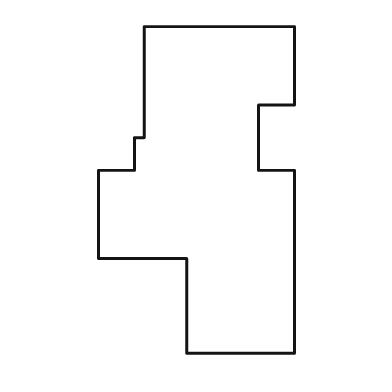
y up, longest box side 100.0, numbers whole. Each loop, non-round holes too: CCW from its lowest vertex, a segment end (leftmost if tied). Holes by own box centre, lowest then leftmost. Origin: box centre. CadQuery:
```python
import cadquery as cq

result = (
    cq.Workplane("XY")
    .moveTo(-3.0, -50.0)
    .lineTo(30.0, -50.0)
    .lineTo(30.0, 6.0)
    .lineTo(19.0, 6.0)
    .lineTo(19.0, 26.0)
    .lineTo(30.0, 26.0)
    .lineTo(30.0, 50.0)
    .lineTo(-16.0, 50.0)
    .lineTo(-16.0, 16.0)
    .lineTo(-19.0, 16.0)
    .lineTo(-19.0, 6.0)
    .lineTo(-30.0, 6.0)
    .lineTo(-30.0, -21.0)
    .lineTo(-3.0, -21.0)
    .close()
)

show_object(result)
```